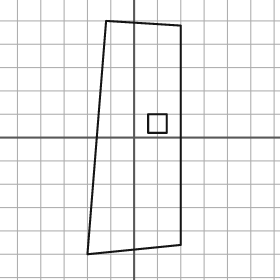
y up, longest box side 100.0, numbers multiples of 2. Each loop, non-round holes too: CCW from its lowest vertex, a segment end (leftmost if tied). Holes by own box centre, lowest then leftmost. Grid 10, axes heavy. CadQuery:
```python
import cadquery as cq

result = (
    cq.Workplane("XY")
    .moveTo(-20.0, -50.0)
    .lineTo(20.0, -46.0)
    .lineTo(20.0, 48.0)
    .lineTo(-12.0, 50.0)
    .close()
    .moveTo(6.0, 2.0)
    .lineTo(14.0, 2.0)
    .lineTo(14.0, 10.0)
    .lineTo(6.0, 10.0)
    .close()
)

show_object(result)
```